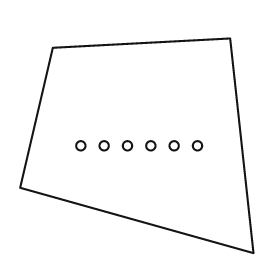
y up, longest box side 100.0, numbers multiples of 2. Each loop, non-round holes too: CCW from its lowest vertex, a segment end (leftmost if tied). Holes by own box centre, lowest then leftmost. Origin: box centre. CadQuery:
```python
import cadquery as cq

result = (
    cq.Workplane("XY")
    .moveTo(50.0, -46.0)
    .lineTo(40.0, 46.0)
    .lineTo(-36.0, 42.0)
    .lineTo(-50.0, -18.0)
    .close()
    .moveTo(-24.0, 0.0)
    .circle(2.0)
    .moveTo(-14.0, 0.0)
    .circle(2.0)
    .moveTo(-4.0, 0.0)
    .circle(2.0)
    .moveTo(6.0, 0.0)
    .circle(2.0)
    .moveTo(16.0, 0.0)
    .circle(2.0)
    .moveTo(26.0, 0.0)
    .circle(2.0)
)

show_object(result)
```